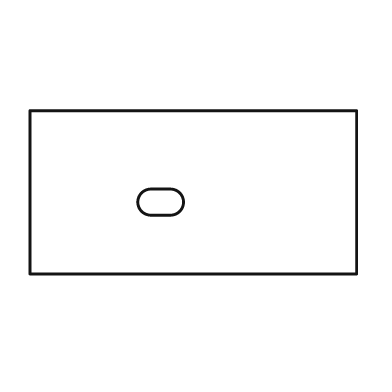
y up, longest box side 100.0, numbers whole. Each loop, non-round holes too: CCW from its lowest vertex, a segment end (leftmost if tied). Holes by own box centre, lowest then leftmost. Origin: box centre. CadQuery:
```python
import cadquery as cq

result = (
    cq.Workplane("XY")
    .moveTo(-50.0, -25.0)
    .lineTo(50.0, -25.0)
    .lineTo(50.0, 25.0)
    .lineTo(-50.0, 25.0)
    .close()
    .moveTo(-13.0, -7.0)
    .lineTo(-7.0, -7.0)
    .threePointArc((-3.0, -3.0), (-7.0, 1.0))
    .lineTo(-13.0, 1.0)
    .threePointArc((-17.0, -3.0), (-13.0, -7.0))
    .close()
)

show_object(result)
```